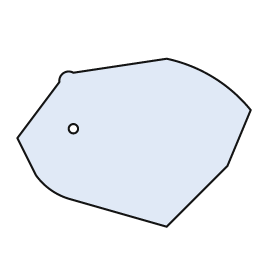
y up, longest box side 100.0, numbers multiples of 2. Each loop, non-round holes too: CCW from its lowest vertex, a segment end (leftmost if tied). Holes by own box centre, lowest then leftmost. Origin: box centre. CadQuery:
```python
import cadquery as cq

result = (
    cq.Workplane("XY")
    .moveTo(14.0, -36.0)
    .lineTo(40.0, -10.0)
    .lineTo(50.0, 14.0)
    .threePointArc((34.0, 28.0), (14.0, 36.0))
    .lineTo(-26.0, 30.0)
    .threePointArc((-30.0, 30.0), (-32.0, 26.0))
    .lineTo(-50.0, 2.0)
    .lineTo(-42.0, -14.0)
    .threePointArc((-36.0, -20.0), (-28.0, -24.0))
    .close()
    .moveTo(-26.0, 6.0)
    .circle(2.0)
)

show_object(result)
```